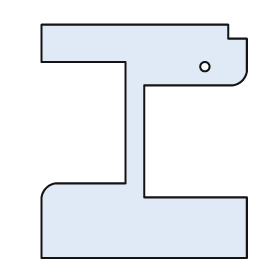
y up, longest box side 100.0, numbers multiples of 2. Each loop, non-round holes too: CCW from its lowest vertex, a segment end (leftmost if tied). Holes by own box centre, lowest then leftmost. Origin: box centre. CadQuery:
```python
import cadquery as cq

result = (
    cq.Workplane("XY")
    .moveTo(-44.0, -50.0)
    .lineTo(44.0, -50.0)
    .lineTo(44.0, -24.0)
    .lineTo(0.0, -24.0)
    .lineTo(0.0, 24.0)
    .lineTo(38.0, 24.0)
    .threePointArc((42.0, 26.0), (44.0, 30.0))
    .lineTo(44.0, 44.0)
    .lineTo(36.0, 44.0)
    .lineTo(36.0, 50.0)
    .lineTo(-44.0, 50.0)
    .lineTo(-44.0, 34.0)
    .lineTo(-8.0, 34.0)
    .lineTo(-8.0, -18.0)
    .lineTo(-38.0, -18.0)
    .threePointArc((-42.0, -20.0), (-44.0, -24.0))
    .close()
    .moveTo(26.0, 32.0)
    .circle(2.0)
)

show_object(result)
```